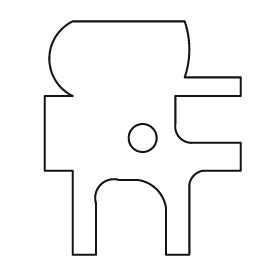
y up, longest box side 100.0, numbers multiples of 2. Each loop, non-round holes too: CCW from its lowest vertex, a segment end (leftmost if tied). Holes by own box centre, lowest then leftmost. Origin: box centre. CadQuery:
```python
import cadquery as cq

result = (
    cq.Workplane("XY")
    .moveTo(-30.0, -50.0)
    .lineTo(-20.0, -50.0)
    .lineTo(-20.0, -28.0)
    .threePointArc((-18.0, -20.0), (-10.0, -18.0))
    .lineTo(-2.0, -18.0)
    .threePointArc((6.0, -22.0), (10.0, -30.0))
    .lineTo(10.0, -50.0)
    .lineTo(20.0, -50.0)
    .lineTo(20.0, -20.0)
    .threePointArc((22.0, -16.0), (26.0, -14.0))
    .lineTo(42.0, -14.0)
    .lineTo(42.0, -2.0)
    .lineTo(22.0, -2.0)
    .threePointArc((16.0, 0.0), (14.0, 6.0))
    .lineTo(14.0, 18.0)
    .lineTo(42.0, 18.0)
    .lineTo(42.0, 26.0)
    .lineTo(18.0, 26.0)
    .threePointArc((20.0, 38.0), (18.0, 50.0))
    .lineTo(-30.0, 50.0)
    .threePointArc((-40.0, 34.0), (-30.0, 18.0))
    .lineTo(-42.0, 18.0)
    .lineTo(-42.0, -14.0)
    .lineTo(-30.0, -14.0)
    .close()
    .moveTo(0.0, 0.0)
    .circle(6.0)
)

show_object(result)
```